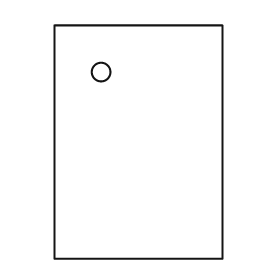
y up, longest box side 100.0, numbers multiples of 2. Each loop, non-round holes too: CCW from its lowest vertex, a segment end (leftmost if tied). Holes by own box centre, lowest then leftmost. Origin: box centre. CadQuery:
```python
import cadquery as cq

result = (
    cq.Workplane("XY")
    .moveTo(-36.0, -50.0)
    .lineTo(36.0, -50.0)
    .lineTo(36.0, 50.0)
    .lineTo(-36.0, 50.0)
    .close()
    .moveTo(-16.0, 30.0)
    .circle(4.0)
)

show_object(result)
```